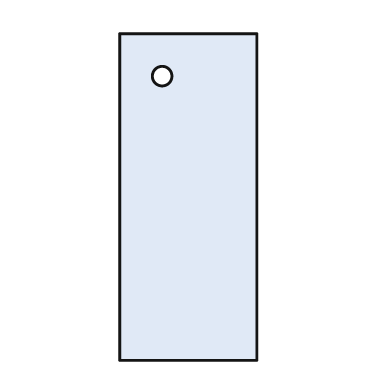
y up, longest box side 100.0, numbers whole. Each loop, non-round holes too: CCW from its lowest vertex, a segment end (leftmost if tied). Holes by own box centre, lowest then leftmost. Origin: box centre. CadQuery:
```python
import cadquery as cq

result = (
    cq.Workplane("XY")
    .moveTo(-21.0, -50.0)
    .lineTo(21.0, -50.0)
    .lineTo(21.0, 50.0)
    .lineTo(-21.0, 50.0)
    .close()
    .moveTo(-8.0, 37.0)
    .circle(3.0)
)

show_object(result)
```